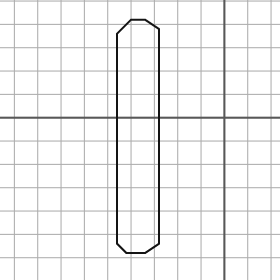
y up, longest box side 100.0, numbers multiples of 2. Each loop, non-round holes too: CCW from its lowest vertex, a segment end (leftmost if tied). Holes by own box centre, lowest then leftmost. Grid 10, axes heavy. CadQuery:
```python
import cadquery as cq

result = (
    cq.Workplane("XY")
    .moveTo(-42.0, -58.0)
    .lineTo(-34.0, -58.0)
    .lineTo(-28.0, -54.0)
    .lineTo(-28.0, 38.0)
    .lineTo(-34.0, 42.0)
    .lineTo(-40.0, 42.0)
    .lineTo(-46.0, 36.0)
    .lineTo(-46.0, -54.0)
    .close()
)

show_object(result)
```